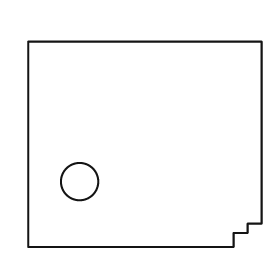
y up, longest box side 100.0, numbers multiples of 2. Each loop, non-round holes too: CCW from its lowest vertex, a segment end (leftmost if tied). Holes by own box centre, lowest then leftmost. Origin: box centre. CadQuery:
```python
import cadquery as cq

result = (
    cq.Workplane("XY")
    .moveTo(-50.0, -44.0)
    .lineTo(38.0, -44.0)
    .lineTo(38.0, -38.0)
    .lineTo(44.0, -38.0)
    .lineTo(44.0, -34.0)
    .lineTo(50.0, -34.0)
    .lineTo(50.0, 44.0)
    .lineTo(-50.0, 44.0)
    .close()
    .moveTo(-28.0, -16.0)
    .circle(8.0)
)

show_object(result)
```